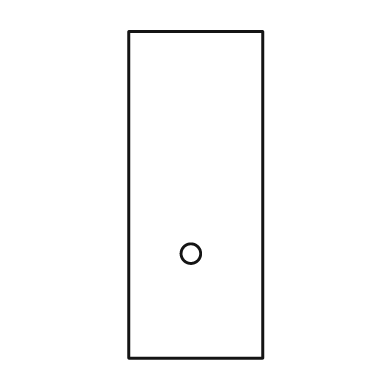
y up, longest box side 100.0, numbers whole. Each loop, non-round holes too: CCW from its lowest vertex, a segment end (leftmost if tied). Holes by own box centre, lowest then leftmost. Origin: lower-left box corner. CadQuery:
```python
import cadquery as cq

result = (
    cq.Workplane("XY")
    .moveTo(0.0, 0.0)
    .lineTo(41.0, 0.0)
    .lineTo(41.0, 100.0)
    .lineTo(0.0, 100.0)
    .close()
    .moveTo(19.0, 32.0)
    .circle(3.0)
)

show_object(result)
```